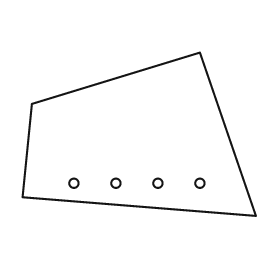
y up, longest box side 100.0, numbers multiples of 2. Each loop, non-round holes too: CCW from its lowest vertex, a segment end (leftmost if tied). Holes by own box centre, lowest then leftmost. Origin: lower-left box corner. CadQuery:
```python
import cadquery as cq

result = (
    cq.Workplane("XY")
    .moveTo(100.0, 0.0)
    .lineTo(76.0, 70.0)
    .lineTo(4.0, 48.0)
    .lineTo(0.0, 8.0)
    .close()
    .moveTo(22.0, 14.0)
    .circle(2.0)
    .moveTo(40.0, 14.0)
    .circle(2.0)
    .moveTo(58.0, 14.0)
    .circle(2.0)
    .moveTo(76.0, 14.0)
    .circle(2.0)
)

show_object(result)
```